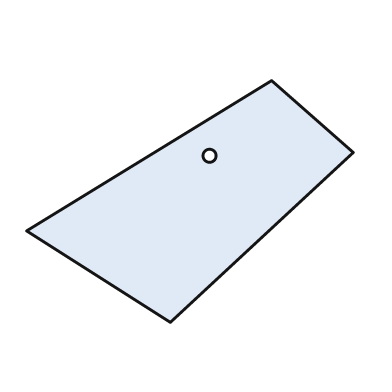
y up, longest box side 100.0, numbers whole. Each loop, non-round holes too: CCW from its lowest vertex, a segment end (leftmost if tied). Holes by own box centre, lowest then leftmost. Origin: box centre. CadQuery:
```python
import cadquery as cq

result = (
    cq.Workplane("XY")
    .moveTo(-6.0, -37.0)
    .lineTo(50.0, 15.0)
    .lineTo(25.0, 37.0)
    .lineTo(-50.0, -9.0)
    .close()
    .moveTo(6.0, 14.0)
    .circle(2.0)
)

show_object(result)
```